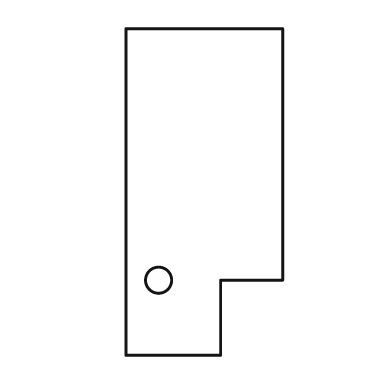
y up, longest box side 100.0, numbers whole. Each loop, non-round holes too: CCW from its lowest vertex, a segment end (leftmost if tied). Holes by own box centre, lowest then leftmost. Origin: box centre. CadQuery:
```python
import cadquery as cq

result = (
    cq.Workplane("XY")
    .moveTo(-24.0, -50.0)
    .lineTo(5.0, -50.0)
    .lineTo(5.0, -27.0)
    .lineTo(24.0, -27.0)
    .lineTo(24.0, 50.0)
    .lineTo(-24.0, 50.0)
    .close()
    .moveTo(-14.0, -27.0)
    .circle(4.0)
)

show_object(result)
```